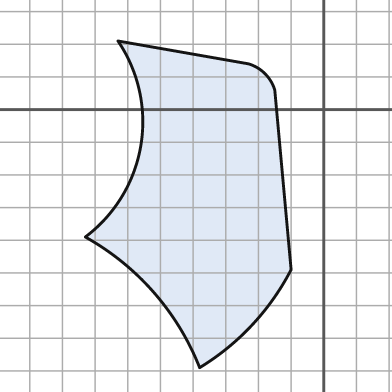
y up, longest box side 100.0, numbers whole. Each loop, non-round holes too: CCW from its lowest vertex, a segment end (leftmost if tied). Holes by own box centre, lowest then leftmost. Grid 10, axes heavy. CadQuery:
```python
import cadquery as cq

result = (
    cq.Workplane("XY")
    .moveTo(-38.0, -79.0)
    .threePointArc((-22.0, -66.0), (-10.0, -49.0))
    .lineTo(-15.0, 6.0)
    .threePointArc((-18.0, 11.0), (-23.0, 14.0))
    .lineTo(-63.0, 21.0)
    .threePointArc((-56.0, -11.0), (-73.0, -39.0))
    .threePointArc((-52.0, -56.0), (-38.0, -79.0))
    .close()
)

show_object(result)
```